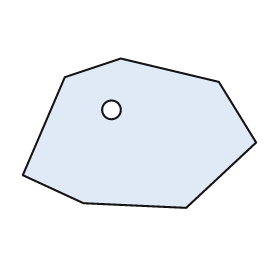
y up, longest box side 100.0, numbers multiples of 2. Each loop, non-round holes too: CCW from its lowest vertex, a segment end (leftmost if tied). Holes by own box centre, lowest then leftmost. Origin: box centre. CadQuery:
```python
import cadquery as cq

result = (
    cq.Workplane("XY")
    .moveTo(20.0, -32.0)
    .lineTo(50.0, -4.0)
    .lineTo(34.0, 22.0)
    .lineTo(-8.0, 32.0)
    .lineTo(-32.0, 24.0)
    .lineTo(-50.0, -18.0)
    .lineTo(-24.0, -30.0)
    .close()
    .moveTo(-12.0, 10.0)
    .circle(4.0)
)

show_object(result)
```